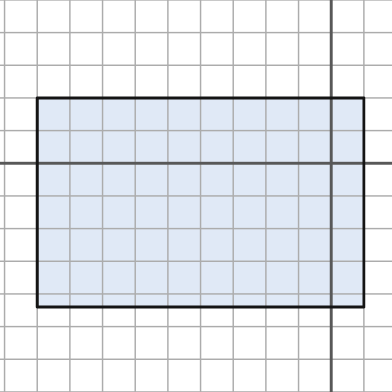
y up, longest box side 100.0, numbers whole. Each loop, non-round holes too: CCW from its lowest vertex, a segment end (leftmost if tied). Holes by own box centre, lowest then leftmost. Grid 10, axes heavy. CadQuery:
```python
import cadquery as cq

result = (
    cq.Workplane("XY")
    .moveTo(-90.0, -44.0)
    .lineTo(10.0, -44.0)
    .lineTo(10.0, 20.0)
    .lineTo(-90.0, 20.0)
    .close()
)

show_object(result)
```